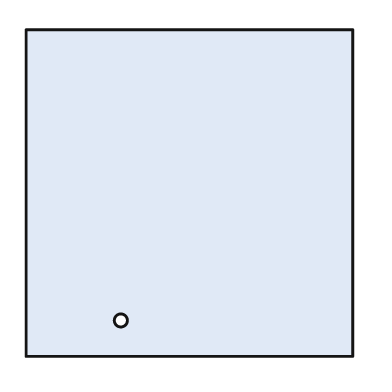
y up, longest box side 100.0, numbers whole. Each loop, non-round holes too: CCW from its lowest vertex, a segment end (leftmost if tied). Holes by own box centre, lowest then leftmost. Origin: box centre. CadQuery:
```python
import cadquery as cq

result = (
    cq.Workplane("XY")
    .moveTo(-50.0, -50.0)
    .lineTo(50.0, -50.0)
    .lineTo(50.0, 50.0)
    .lineTo(-50.0, 50.0)
    .close()
    .moveTo(-21.0, -39.0)
    .circle(2.0)
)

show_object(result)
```